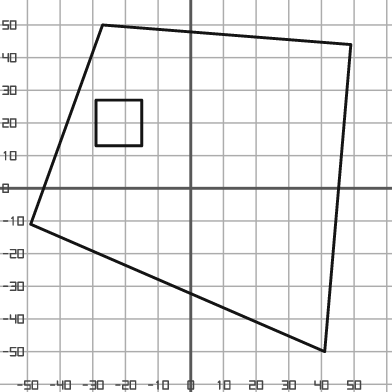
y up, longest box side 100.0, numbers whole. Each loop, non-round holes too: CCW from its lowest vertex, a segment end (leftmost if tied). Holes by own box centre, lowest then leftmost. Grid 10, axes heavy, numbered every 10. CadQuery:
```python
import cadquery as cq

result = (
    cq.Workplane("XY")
    .moveTo(41.0, -50.0)
    .lineTo(49.0, 44.0)
    .lineTo(-27.0, 50.0)
    .lineTo(-49.0, -11.0)
    .close()
    .moveTo(-29.0, 13.0)
    .lineTo(-15.0, 13.0)
    .lineTo(-15.0, 27.0)
    .lineTo(-29.0, 27.0)
    .close()
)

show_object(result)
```